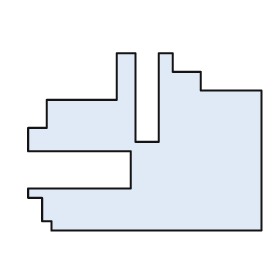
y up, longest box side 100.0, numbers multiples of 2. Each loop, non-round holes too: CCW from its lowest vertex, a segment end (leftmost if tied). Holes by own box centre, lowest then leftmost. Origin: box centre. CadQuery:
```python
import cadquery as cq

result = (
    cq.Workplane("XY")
    .moveTo(-40.0, -38.0)
    .lineTo(50.0, -38.0)
    .lineTo(50.0, 22.0)
    .lineTo(24.0, 22.0)
    .lineTo(24.0, 30.0)
    .lineTo(12.0, 30.0)
    .lineTo(12.0, 38.0)
    .lineTo(6.0, 38.0)
    .lineTo(6.0, 0.0)
    .lineTo(-4.0, 0.0)
    .lineTo(-4.0, 38.0)
    .lineTo(-12.0, 38.0)
    .lineTo(-12.0, 18.0)
    .lineTo(-42.0, 18.0)
    .lineTo(-42.0, 6.0)
    .lineTo(-50.0, 6.0)
    .lineTo(-50.0, -4.0)
    .lineTo(-6.0, -4.0)
    .lineTo(-6.0, -20.0)
    .lineTo(-50.0, -20.0)
    .lineTo(-50.0, -24.0)
    .lineTo(-44.0, -24.0)
    .lineTo(-44.0, -34.0)
    .lineTo(-40.0, -34.0)
    .close()
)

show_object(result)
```